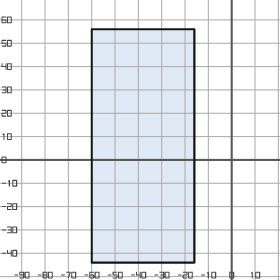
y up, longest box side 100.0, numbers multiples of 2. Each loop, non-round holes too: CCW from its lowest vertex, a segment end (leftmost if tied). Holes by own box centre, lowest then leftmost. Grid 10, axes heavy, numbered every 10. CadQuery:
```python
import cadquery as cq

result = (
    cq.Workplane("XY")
    .moveTo(-60.0, -44.0)
    .lineTo(-16.0, -44.0)
    .lineTo(-16.0, 56.0)
    .lineTo(-60.0, 56.0)
    .close()
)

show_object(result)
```